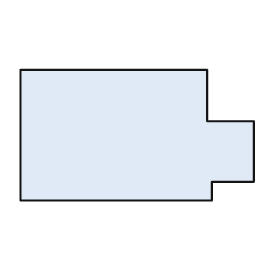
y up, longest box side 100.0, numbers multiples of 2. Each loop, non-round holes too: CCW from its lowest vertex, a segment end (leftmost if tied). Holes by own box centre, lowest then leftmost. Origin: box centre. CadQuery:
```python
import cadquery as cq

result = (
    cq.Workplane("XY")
    .moveTo(-50.0, -28.0)
    .lineTo(32.0, -28.0)
    .lineTo(32.0, -20.0)
    .lineTo(50.0, -20.0)
    .lineTo(50.0, 6.0)
    .lineTo(30.0, 6.0)
    .lineTo(30.0, 28.0)
    .lineTo(-50.0, 28.0)
    .close()
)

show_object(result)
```